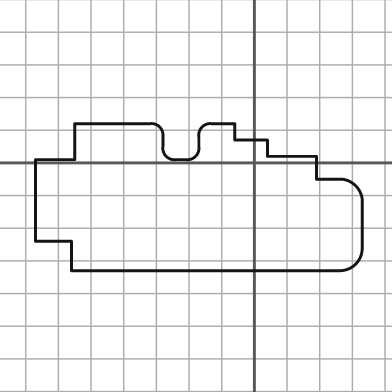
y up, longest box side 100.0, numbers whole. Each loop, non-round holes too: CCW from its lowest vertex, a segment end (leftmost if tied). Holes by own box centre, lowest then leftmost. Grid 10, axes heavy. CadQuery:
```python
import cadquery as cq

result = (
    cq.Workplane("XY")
    .moveTo(-56.0, -33.0)
    .lineTo(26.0, -33.0)
    .threePointArc((31.0, -31.0), (33.0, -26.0))
    .lineTo(33.0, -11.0)
    .threePointArc((31.0, -7.0), (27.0, -5.0))
    .lineTo(19.0, -5.0)
    .lineTo(19.0, 2.0)
    .lineTo(4.0, 2.0)
    .lineTo(4.0, 7.0)
    .lineTo(-6.0, 7.0)
    .lineTo(-6.0, 12.0)
    .lineTo(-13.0, 12.0)
    .threePointArc((-16.0, 11.0), (-17.0, 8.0))
    .lineTo(-17.0, 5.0)
    .threePointArc((-18.0, 2.0), (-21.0, 1.0))
    .lineTo(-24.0, 1.0)
    .threePointArc((-27.0, 2.0), (-28.0, 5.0))
    .lineTo(-28.0, 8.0)
    .threePointArc((-29.0, 11.0), (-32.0, 12.0))
    .lineTo(-55.0, 12.0)
    .lineTo(-55.0, 1.0)
    .lineTo(-67.0, 1.0)
    .lineTo(-67.0, -24.0)
    .lineTo(-56.0, -24.0)
    .close()
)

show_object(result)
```